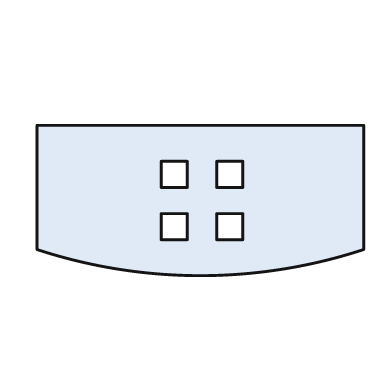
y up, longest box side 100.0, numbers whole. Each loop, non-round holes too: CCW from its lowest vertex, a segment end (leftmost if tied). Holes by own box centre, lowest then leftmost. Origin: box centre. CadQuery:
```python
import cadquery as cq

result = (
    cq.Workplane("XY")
    .moveTo(-50.0, -15.0)
    .threePointArc((0.0, -23.0), (50.0, -15.0))
    .lineTo(50.0, 23.0)
    .lineTo(-50.0, 23.0)
    .close()
    .moveTo(-12.0, -12.0)
    .lineTo(-4.0, -12.0)
    .lineTo(-4.0, -4.0)
    .lineTo(-12.0, -4.0)
    .close()
    .moveTo(5.0, -12.0)
    .lineTo(13.0, -12.0)
    .lineTo(13.0, -4.0)
    .lineTo(5.0, -4.0)
    .close()
    .moveTo(-12.0, 4.0)
    .lineTo(-4.0, 4.0)
    .lineTo(-4.0, 12.0)
    .lineTo(-12.0, 12.0)
    .close()
    .moveTo(5.0, 4.0)
    .lineTo(13.0, 4.0)
    .lineTo(13.0, 12.0)
    .lineTo(5.0, 12.0)
    .close()
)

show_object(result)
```